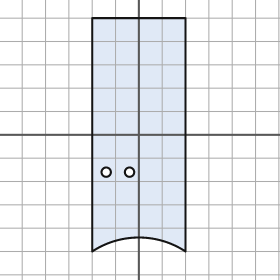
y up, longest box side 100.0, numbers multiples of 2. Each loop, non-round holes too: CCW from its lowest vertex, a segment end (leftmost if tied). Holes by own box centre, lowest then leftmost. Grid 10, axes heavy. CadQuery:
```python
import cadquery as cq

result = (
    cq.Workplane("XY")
    .moveTo(-20.0, -50.0)
    .threePointArc((0.0, -44.0), (20.0, -50.0))
    .lineTo(20.0, 50.0)
    .lineTo(-20.0, 50.0)
    .close()
    .moveTo(-14.0, -16.0)
    .circle(2.0)
    .moveTo(-4.0, -16.0)
    .circle(2.0)
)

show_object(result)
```